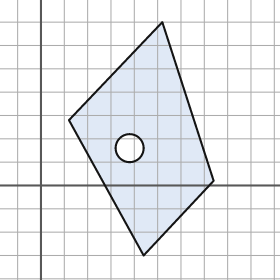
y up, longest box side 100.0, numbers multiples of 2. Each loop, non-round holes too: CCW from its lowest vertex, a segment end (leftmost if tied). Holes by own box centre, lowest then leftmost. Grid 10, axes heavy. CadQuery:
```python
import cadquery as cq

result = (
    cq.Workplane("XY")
    .moveTo(44.0, -30.0)
    .lineTo(74.0, 2.0)
    .lineTo(52.0, 70.0)
    .lineTo(12.0, 28.0)
    .close()
    .moveTo(38.0, 16.0)
    .circle(6.0)
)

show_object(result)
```